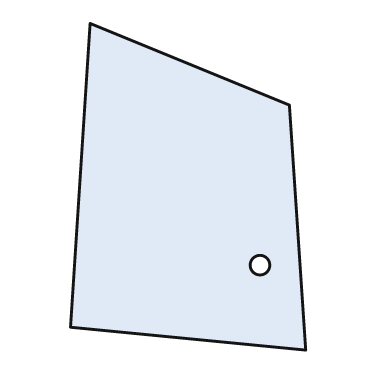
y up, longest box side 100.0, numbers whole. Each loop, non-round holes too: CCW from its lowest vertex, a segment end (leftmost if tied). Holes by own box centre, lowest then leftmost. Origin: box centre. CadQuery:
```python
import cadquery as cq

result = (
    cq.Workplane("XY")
    .moveTo(36.0, -50.0)
    .lineTo(31.0, 25.0)
    .lineTo(-30.0, 50.0)
    .lineTo(-36.0, -43.0)
    .close()
    .moveTo(22.0, -24.0)
    .circle(3.0)
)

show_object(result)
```